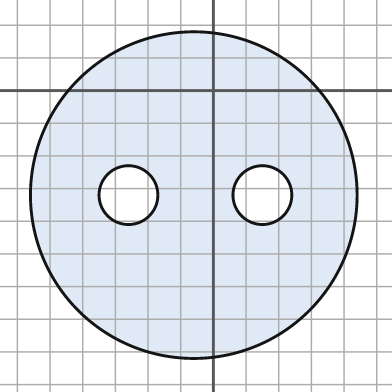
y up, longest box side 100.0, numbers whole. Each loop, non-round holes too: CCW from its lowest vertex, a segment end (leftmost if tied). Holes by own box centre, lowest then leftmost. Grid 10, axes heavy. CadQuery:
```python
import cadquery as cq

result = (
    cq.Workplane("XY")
    .moveTo(-6.0, -32.0)
    .circle(50.0)
    .moveTo(-26.0, -32.0)
    .circle(9.0)
    .moveTo(15.0, -32.0)
    .circle(9.0)
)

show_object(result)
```